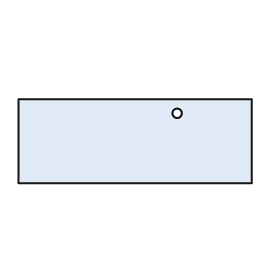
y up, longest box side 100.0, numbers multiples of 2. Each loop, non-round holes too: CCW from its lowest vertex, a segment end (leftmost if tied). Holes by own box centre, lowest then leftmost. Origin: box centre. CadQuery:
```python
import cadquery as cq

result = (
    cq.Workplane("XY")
    .moveTo(-50.0, -18.0)
    .lineTo(50.0, -18.0)
    .lineTo(50.0, 18.0)
    .lineTo(-50.0, 18.0)
    .close()
    .moveTo(18.0, 12.0)
    .circle(2.0)
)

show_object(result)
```